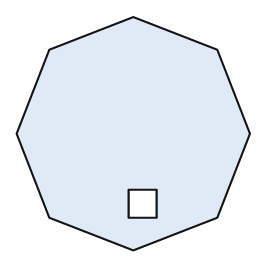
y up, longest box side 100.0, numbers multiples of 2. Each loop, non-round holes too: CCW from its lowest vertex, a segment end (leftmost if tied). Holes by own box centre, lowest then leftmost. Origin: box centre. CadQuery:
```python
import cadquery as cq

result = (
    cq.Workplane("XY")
    .moveTo(0.0, -50.0)
    .lineTo(36.0, -36.0)
    .lineTo(50.0, 0.0)
    .lineTo(36.0, 36.0)
    .lineTo(0.0, 50.0)
    .lineTo(-36.0, 36.0)
    .lineTo(-50.0, 0.0)
    .lineTo(-36.0, -36.0)
    .close()
    .moveTo(-2.0, -36.0)
    .lineTo(10.0, -36.0)
    .lineTo(10.0, -24.0)
    .lineTo(-2.0, -24.0)
    .close()
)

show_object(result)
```